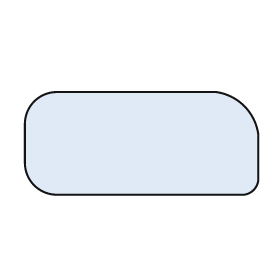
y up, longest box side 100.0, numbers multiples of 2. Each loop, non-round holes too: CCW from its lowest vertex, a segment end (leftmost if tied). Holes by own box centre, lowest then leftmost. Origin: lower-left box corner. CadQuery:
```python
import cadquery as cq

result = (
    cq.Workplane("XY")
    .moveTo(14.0, 0.0)
    .lineTo(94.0, 0.0)
    .threePointArc((98.0, 2.0), (100.0, 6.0))
    .lineTo(100.0, 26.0)
    .threePointArc((94.0, 38.0), (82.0, 44.0))
    .lineTo(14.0, 44.0)
    .threePointArc((4.0, 40.0), (0.0, 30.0))
    .lineTo(0.0, 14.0)
    .threePointArc((4.0, 4.0), (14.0, 0.0))
    .close()
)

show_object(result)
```